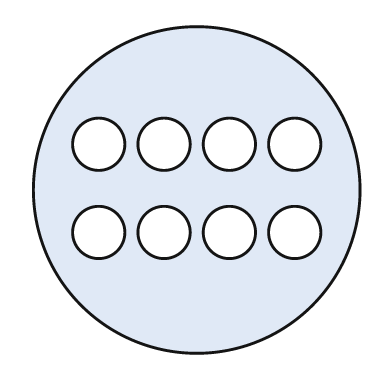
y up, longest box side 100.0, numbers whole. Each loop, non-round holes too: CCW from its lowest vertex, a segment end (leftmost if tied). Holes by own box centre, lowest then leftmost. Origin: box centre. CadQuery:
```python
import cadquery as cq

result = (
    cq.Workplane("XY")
    .moveTo(0.0, 0.0)
    .circle(50.0)
    .moveTo(-30.0, -13.0)
    .circle(8.0)
    .moveTo(-10.0, -13.0)
    .circle(8.0)
    .moveTo(10.0, -13.0)
    .circle(8.0)
    .moveTo(30.0, -13.0)
    .circle(8.0)
    .moveTo(-30.0, 14.0)
    .circle(8.0)
    .moveTo(-10.0, 14.0)
    .circle(8.0)
    .moveTo(10.0, 14.0)
    .circle(8.0)
    .moveTo(30.0, 14.0)
    .circle(8.0)
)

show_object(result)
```